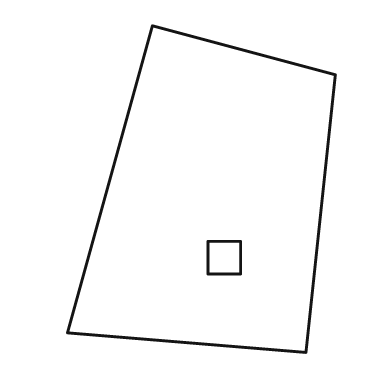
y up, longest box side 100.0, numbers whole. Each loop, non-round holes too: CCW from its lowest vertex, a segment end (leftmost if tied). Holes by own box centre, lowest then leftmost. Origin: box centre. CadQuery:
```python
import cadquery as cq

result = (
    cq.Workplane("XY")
    .moveTo(32.0, -50.0)
    .lineTo(41.0, 35.0)
    .lineTo(-15.0, 50.0)
    .lineTo(-41.0, -44.0)
    .close()
    .moveTo(2.0, -26.0)
    .lineTo(12.0, -26.0)
    .lineTo(12.0, -16.0)
    .lineTo(2.0, -16.0)
    .close()
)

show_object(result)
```